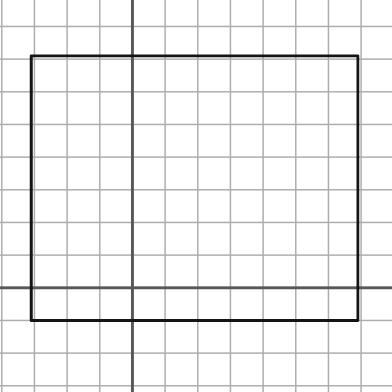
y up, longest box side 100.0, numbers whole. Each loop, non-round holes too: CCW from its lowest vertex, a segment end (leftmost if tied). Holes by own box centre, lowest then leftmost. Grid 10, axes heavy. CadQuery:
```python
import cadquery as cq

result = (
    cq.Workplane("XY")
    .moveTo(-31.0, -10.0)
    .lineTo(69.0, -10.0)
    .lineTo(69.0, 71.0)
    .lineTo(-31.0, 71.0)
    .close()
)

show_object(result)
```